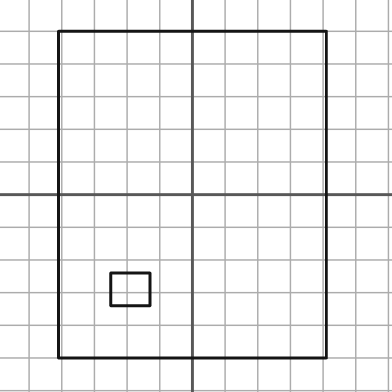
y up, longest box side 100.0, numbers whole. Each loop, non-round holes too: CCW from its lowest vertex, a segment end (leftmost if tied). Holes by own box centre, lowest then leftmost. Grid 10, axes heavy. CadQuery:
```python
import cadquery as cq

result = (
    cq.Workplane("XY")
    .moveTo(-41.0, -50.0)
    .lineTo(41.0, -50.0)
    .lineTo(41.0, 50.0)
    .lineTo(-41.0, 50.0)
    .close()
    .moveTo(-25.0, -34.0)
    .lineTo(-13.0, -34.0)
    .lineTo(-13.0, -24.0)
    .lineTo(-25.0, -24.0)
    .close()
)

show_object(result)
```